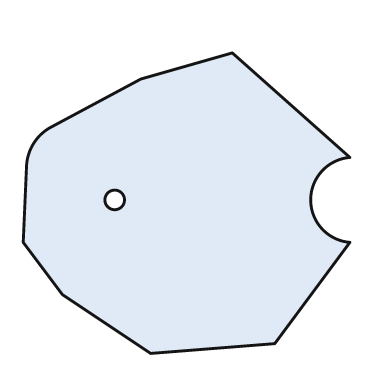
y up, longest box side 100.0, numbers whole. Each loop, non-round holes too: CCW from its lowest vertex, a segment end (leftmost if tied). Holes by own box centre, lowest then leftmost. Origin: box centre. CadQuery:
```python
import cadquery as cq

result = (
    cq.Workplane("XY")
    .moveTo(-11.0, -46.0)
    .lineTo(27.0, -43.0)
    .lineTo(50.0, -12.0)
    .threePointArc((38.0, 1.0), (50.0, 14.0))
    .lineTo(14.0, 46.0)
    .lineTo(-14.0, 38.0)
    .lineTo(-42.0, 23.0)
    .threePointArc((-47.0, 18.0), (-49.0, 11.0))
    .lineTo(-50.0, -12.0)
    .lineTo(-38.0, -28.0)
    .close()
    .moveTo(-22.0, 1.0)
    .circle(3.0)
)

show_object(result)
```